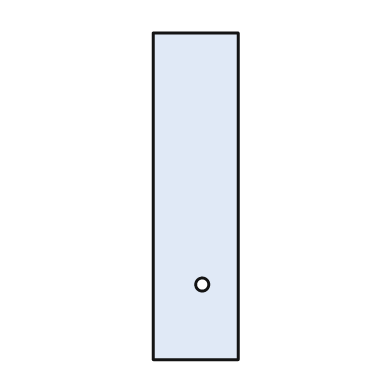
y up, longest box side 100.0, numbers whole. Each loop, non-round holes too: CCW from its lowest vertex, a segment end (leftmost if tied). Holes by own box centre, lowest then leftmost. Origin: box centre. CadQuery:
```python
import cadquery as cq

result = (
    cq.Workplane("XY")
    .moveTo(-13.0, -50.0)
    .lineTo(13.0, -50.0)
    .lineTo(13.0, 50.0)
    .lineTo(-13.0, 50.0)
    .close()
    .moveTo(2.0, -27.0)
    .circle(2.0)
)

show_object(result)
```